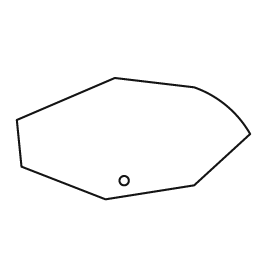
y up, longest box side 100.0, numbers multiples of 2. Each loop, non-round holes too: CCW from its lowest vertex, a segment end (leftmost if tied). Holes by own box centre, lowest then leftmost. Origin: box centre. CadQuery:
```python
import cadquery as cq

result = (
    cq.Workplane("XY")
    .moveTo(-12.0, -26.0)
    .lineTo(26.0, -20.0)
    .lineTo(50.0, 2.0)
    .threePointArc((40.0, 14.0), (26.0, 22.0))
    .lineTo(-8.0, 26.0)
    .lineTo(-50.0, 8.0)
    .lineTo(-48.0, -12.0)
    .close()
    .moveTo(-4.0, -18.0)
    .circle(2.0)
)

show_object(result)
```